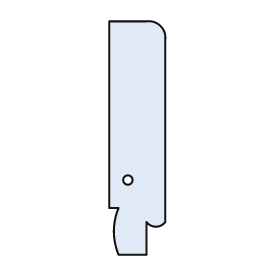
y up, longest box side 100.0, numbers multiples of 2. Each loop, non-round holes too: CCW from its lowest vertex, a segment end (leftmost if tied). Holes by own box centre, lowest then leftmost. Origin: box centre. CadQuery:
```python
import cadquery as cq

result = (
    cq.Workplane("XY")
    .moveTo(-8.0, -50.0)
    .lineTo(4.0, -50.0)
    .lineTo(4.0, -36.0)
    .threePointArc((8.0, -38.0), (12.0, -36.0))
    .lineTo(12.0, 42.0)
    .threePointArc((10.0, 48.0), (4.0, 50.0))
    .lineTo(-12.0, 50.0)
    .lineTo(-12.0, -30.0)
    .lineTo(-8.0, -30.0)
    .threePointArc((-10.0, -40.0), (-8.0, -50.0))
    .close()
    .moveTo(-4.0, -18.0)
    .circle(2.0)
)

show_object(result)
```